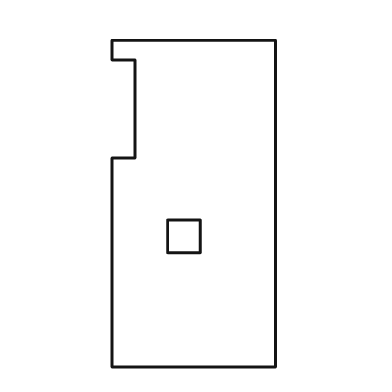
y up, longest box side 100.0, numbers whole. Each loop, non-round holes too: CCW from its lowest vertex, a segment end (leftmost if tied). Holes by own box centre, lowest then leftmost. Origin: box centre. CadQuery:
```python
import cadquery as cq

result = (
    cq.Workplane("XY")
    .moveTo(-25.0, -50.0)
    .lineTo(25.0, -50.0)
    .lineTo(25.0, 50.0)
    .lineTo(-25.0, 50.0)
    .lineTo(-25.0, 44.0)
    .lineTo(-18.0, 44.0)
    .lineTo(-18.0, 14.0)
    .lineTo(-25.0, 14.0)
    .close()
    .moveTo(-8.0, -15.0)
    .lineTo(2.0, -15.0)
    .lineTo(2.0, -5.0)
    .lineTo(-8.0, -5.0)
    .close()
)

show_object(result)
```